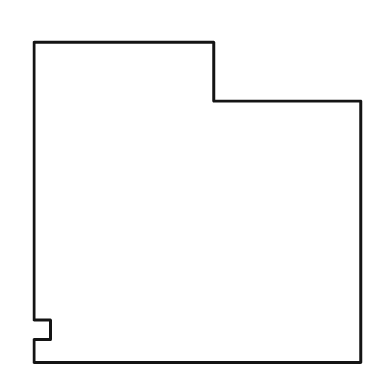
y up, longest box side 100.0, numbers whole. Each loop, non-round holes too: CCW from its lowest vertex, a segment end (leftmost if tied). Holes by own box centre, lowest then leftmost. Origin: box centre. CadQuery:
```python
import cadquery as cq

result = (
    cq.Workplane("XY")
    .moveTo(-50.0, -49.0)
    .lineTo(50.0, -49.0)
    .lineTo(50.0, 31.0)
    .lineTo(5.0, 31.0)
    .lineTo(5.0, 49.0)
    .lineTo(-50.0, 49.0)
    .lineTo(-50.0, -36.0)
    .lineTo(-45.0, -36.0)
    .lineTo(-45.0, -42.0)
    .lineTo(-50.0, -42.0)
    .close()
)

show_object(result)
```